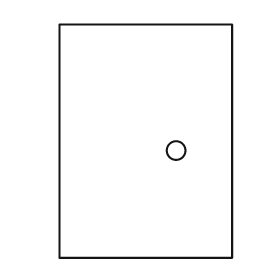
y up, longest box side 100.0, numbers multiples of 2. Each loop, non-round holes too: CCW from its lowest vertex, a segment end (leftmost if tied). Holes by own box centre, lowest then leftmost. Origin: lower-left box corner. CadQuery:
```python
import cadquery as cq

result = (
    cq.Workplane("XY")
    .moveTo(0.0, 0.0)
    .lineTo(74.0, 0.0)
    .lineTo(74.0, 100.0)
    .lineTo(0.0, 100.0)
    .close()
    .moveTo(50.0, 46.0)
    .circle(4.0)
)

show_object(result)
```